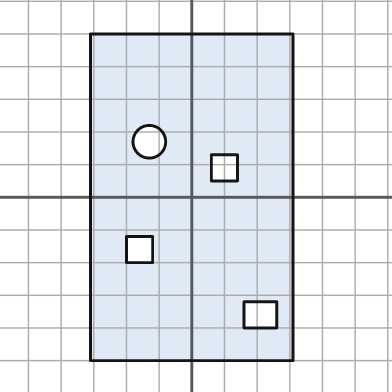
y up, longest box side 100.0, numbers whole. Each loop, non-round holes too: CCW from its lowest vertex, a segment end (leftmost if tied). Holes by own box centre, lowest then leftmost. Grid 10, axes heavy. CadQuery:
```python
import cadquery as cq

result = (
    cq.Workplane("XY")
    .moveTo(-31.0, -50.0)
    .lineTo(31.0, -50.0)
    .lineTo(31.0, 50.0)
    .lineTo(-31.0, 50.0)
    .close()
    .moveTo(16.0, -40.0)
    .lineTo(26.0, -40.0)
    .lineTo(26.0, -32.0)
    .lineTo(16.0, -32.0)
    .close()
    .moveTo(-20.0, -20.0)
    .lineTo(-12.0, -20.0)
    .lineTo(-12.0, -12.0)
    .lineTo(-20.0, -12.0)
    .close()
    .moveTo(6.0, 5.0)
    .lineTo(14.0, 5.0)
    .lineTo(14.0, 13.0)
    .lineTo(6.0, 13.0)
    .close()
    .moveTo(-13.0, 17.0)
    .circle(5.0)
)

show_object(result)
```